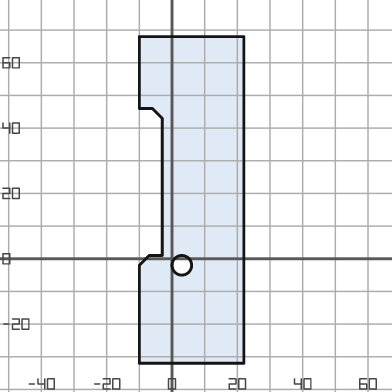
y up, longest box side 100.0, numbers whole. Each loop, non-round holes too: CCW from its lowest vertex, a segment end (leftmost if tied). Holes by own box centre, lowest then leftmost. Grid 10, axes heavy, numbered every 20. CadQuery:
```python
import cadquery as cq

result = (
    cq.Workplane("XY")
    .moveTo(-10.0, -32.0)
    .lineTo(22.0, -32.0)
    .lineTo(22.0, 68.0)
    .lineTo(-10.0, 68.0)
    .lineTo(-10.0, 46.0)
    .lineTo(-6.0, 46.0)
    .lineTo(-3.0, 43.0)
    .lineTo(-3.0, 1.0)
    .lineTo(-7.0, 1.0)
    .lineTo(-10.0, -2.0)
    .close()
    .moveTo(3.0, -2.0)
    .circle(3.0)
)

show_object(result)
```